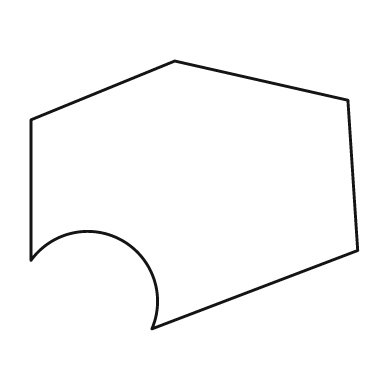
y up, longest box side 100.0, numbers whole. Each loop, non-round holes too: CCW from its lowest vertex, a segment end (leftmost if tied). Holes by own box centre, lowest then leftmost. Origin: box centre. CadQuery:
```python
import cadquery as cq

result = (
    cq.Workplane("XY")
    .moveTo(-13.0, -41.0)
    .lineTo(50.0, -17.0)
    .lineTo(47.0, 29.0)
    .lineTo(-6.0, 41.0)
    .lineTo(-50.0, 23.0)
    .lineTo(-50.0, -20.0)
    .threePointArc((-22.0, -14.0), (-13.0, -41.0))
    .close()
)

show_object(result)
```